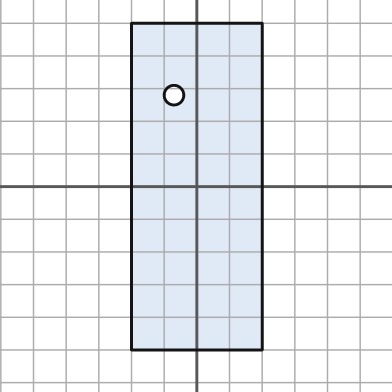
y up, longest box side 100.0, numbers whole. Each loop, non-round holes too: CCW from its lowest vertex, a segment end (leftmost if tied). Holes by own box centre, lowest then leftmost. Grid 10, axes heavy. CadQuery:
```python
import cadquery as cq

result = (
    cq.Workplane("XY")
    .moveTo(-20.0, -50.0)
    .lineTo(20.0, -50.0)
    .lineTo(20.0, 50.0)
    .lineTo(-20.0, 50.0)
    .close()
    .moveTo(-7.0, 28.0)
    .circle(3.0)
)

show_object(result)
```